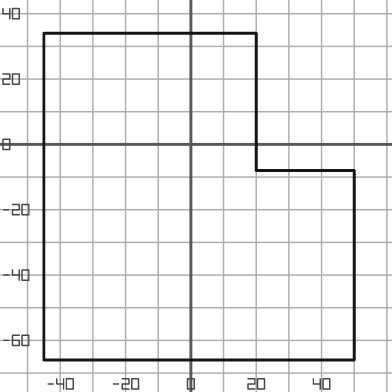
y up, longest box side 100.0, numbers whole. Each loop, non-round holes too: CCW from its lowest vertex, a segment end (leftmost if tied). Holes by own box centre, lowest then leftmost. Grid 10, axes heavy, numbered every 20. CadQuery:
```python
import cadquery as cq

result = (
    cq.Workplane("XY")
    .moveTo(-45.0, -66.0)
    .lineTo(50.0, -66.0)
    .lineTo(50.0, -8.0)
    .lineTo(20.0, -8.0)
    .lineTo(20.0, 34.0)
    .lineTo(-45.0, 34.0)
    .close()
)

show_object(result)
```